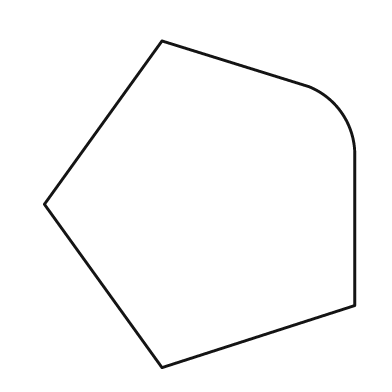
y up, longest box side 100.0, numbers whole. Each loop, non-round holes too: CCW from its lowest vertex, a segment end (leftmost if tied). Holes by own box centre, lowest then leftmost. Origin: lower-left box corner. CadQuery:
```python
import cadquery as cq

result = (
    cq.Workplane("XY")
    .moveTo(36.0, 0.0)
    .lineTo(95.0, 19.0)
    .lineTo(95.0, 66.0)
    .threePointArc((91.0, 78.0), (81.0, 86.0))
    .lineTo(36.0, 100.0)
    .lineTo(0.0, 50.0)
    .close()
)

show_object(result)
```